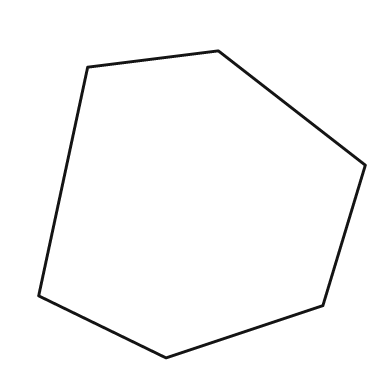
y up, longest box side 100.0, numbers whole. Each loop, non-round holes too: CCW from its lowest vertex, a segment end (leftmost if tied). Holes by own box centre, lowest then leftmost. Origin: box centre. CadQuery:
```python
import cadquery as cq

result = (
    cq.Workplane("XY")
    .moveTo(-11.0, -47.0)
    .lineTo(37.0, -31.0)
    .lineTo(50.0, 12.0)
    .lineTo(5.0, 47.0)
    .lineTo(-35.0, 42.0)
    .lineTo(-50.0, -28.0)
    .close()
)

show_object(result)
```